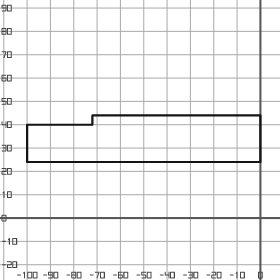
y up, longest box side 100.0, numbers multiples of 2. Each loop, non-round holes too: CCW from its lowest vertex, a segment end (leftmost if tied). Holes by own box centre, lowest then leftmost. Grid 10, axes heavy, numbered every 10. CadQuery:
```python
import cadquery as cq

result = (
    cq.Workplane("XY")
    .moveTo(-100.0, 24.0)
    .lineTo(0.0, 24.0)
    .lineTo(0.0, 44.0)
    .lineTo(-72.0, 44.0)
    .lineTo(-72.0, 40.0)
    .lineTo(-100.0, 40.0)
    .close()
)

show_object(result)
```